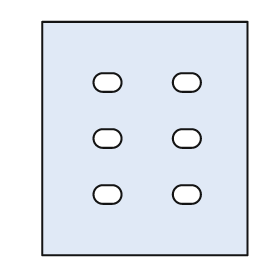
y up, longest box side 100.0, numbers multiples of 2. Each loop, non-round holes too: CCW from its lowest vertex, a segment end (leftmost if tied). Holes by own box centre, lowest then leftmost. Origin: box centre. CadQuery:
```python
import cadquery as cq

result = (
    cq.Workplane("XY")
    .moveTo(-44.0, -50.0)
    .lineTo(44.0, -50.0)
    .lineTo(44.0, 50.0)
    .lineTo(-44.0, 50.0)
    .close()
    .moveTo(-18.0, -28.0)
    .lineTo(-14.0, -28.0)
    .threePointArc((-10.0, -24.0), (-14.0, -20.0))
    .lineTo(-18.0, -20.0)
    .threePointArc((-22.0, -24.0), (-18.0, -28.0))
    .close()
    .moveTo(16.0, -28.0)
    .lineTo(20.0, -28.0)
    .threePointArc((24.0, -24.0), (20.0, -20.0))
    .lineTo(16.0, -20.0)
    .threePointArc((12.0, -24.0), (16.0, -28.0))
    .close()
    .moveTo(-18.0, -4.0)
    .lineTo(-14.0, -4.0)
    .threePointArc((-10.0, 0.0), (-14.0, 4.0))
    .lineTo(-18.0, 4.0)
    .threePointArc((-22.0, 0.0), (-18.0, -4.0))
    .close()
    .moveTo(16.0, -4.0)
    .lineTo(20.0, -4.0)
    .threePointArc((24.0, 0.0), (20.0, 4.0))
    .lineTo(16.0, 4.0)
    .threePointArc((12.0, 0.0), (16.0, -4.0))
    .close()
    .moveTo(-18.0, 20.0)
    .lineTo(-14.0, 20.0)
    .threePointArc((-10.0, 24.0), (-14.0, 28.0))
    .lineTo(-18.0, 28.0)
    .threePointArc((-22.0, 24.0), (-18.0, 20.0))
    .close()
    .moveTo(16.0, 20.0)
    .lineTo(20.0, 20.0)
    .threePointArc((24.0, 24.0), (20.0, 28.0))
    .lineTo(16.0, 28.0)
    .threePointArc((12.0, 24.0), (16.0, 20.0))
    .close()
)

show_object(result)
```